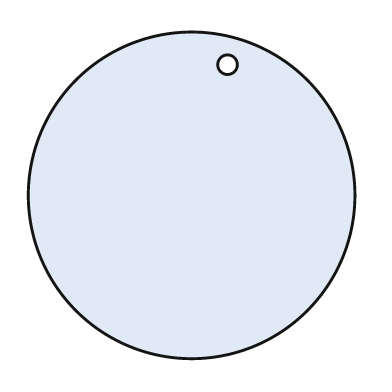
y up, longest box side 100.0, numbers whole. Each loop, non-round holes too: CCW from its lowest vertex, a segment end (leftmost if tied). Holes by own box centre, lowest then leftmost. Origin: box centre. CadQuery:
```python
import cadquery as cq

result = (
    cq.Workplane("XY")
    .moveTo(0.0, 0.0)
    .circle(50.0)
    .moveTo(11.0, 40.0)
    .circle(3.0)
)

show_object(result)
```